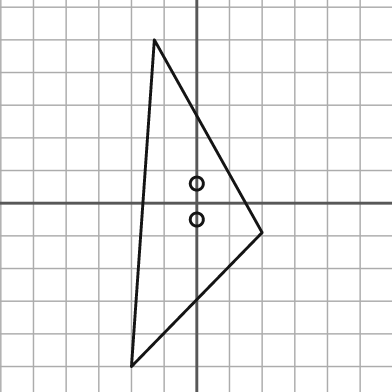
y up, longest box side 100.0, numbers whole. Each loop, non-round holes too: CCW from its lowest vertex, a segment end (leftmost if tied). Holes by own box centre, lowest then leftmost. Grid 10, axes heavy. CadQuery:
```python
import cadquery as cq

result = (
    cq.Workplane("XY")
    .moveTo(-20.0, -50.0)
    .lineTo(20.0, -9.0)
    .lineTo(-13.0, 50.0)
    .close()
    .moveTo(0.0, -5.0)
    .circle(2.0)
    .moveTo(0.0, 6.0)
    .circle(2.0)
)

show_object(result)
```